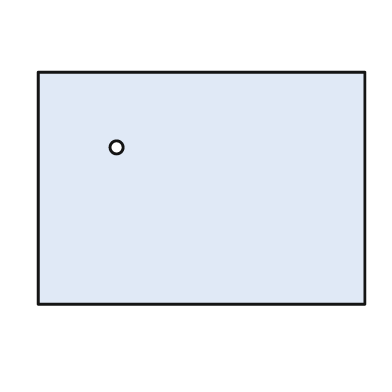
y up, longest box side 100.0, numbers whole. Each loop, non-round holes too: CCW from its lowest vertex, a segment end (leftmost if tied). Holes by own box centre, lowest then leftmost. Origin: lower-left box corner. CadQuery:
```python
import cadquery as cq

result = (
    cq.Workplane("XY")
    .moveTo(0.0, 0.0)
    .lineTo(100.0, 0.0)
    .lineTo(100.0, 71.0)
    .lineTo(0.0, 71.0)
    .close()
    .moveTo(24.0, 48.0)
    .circle(2.0)
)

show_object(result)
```